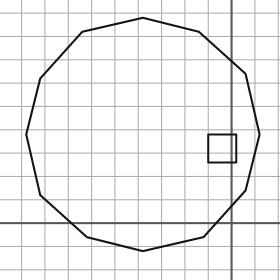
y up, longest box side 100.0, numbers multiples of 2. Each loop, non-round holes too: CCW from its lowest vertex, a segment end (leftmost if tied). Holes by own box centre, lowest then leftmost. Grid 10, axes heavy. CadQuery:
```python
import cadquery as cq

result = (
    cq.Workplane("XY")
    .moveTo(-38.0, -12.0)
    .lineTo(-12.0, -6.0)
    .lineTo(6.0, 14.0)
    .lineTo(12.0, 38.0)
    .lineTo(6.0, 64.0)
    .lineTo(-14.0, 82.0)
    .lineTo(-38.0, 88.0)
    .lineTo(-64.0, 82.0)
    .lineTo(-82.0, 62.0)
    .lineTo(-88.0, 38.0)
    .lineTo(-82.0, 12.0)
    .lineTo(-62.0, -6.0)
    .close()
    .moveTo(-10.0, 26.0)
    .lineTo(2.0, 26.0)
    .lineTo(2.0, 38.0)
    .lineTo(-10.0, 38.0)
    .close()
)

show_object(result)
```